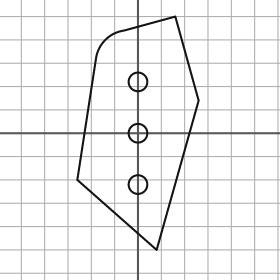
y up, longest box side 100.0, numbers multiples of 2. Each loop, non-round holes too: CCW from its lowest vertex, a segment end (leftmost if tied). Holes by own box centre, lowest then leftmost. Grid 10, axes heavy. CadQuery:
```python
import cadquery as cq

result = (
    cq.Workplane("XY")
    .moveTo(8.0, -50.0)
    .lineTo(26.0, 14.0)
    .lineTo(16.0, 50.0)
    .lineTo(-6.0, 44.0)
    .threePointArc((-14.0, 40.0), (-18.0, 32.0))
    .lineTo(-26.0, -20.0)
    .close()
    .moveTo(0.0, -22.0)
    .circle(4.0)
    .moveTo(0.0, 0.0)
    .circle(4.0)
    .moveTo(0.0, 22.0)
    .circle(4.0)
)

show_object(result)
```